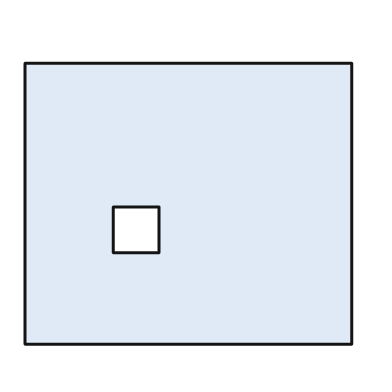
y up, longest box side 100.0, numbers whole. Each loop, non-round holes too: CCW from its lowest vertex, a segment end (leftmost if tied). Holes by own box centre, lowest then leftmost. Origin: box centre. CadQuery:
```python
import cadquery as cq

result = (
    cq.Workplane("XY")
    .moveTo(-50.0, -43.0)
    .lineTo(50.0, -43.0)
    .lineTo(50.0, 43.0)
    .lineTo(-50.0, 43.0)
    .close()
    .moveTo(-23.0, -15.0)
    .lineTo(-9.0, -15.0)
    .lineTo(-9.0, -1.0)
    .lineTo(-23.0, -1.0)
    .close()
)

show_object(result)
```